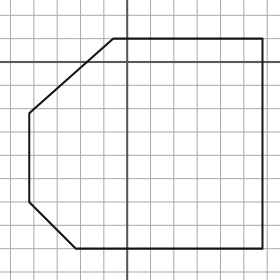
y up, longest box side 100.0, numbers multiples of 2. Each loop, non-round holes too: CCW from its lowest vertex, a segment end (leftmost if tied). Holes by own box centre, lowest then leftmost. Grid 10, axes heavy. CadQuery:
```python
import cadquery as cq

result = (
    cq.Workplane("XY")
    .moveTo(-22.0, -80.0)
    .lineTo(58.0, -80.0)
    .lineTo(58.0, 10.0)
    .lineTo(-6.0, 10.0)
    .lineTo(-42.0, -22.0)
    .lineTo(-42.0, -60.0)
    .close()
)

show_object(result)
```